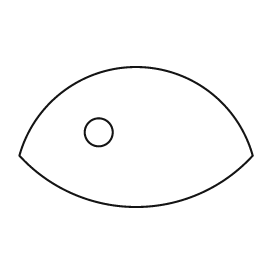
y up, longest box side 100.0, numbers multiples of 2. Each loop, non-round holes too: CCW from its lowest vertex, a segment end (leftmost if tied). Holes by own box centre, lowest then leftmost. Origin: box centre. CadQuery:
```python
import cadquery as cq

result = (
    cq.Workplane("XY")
    .moveTo(-50.0, -8.0)
    .threePointArc((0.0, -30.0), (50.0, -8.0))
    .threePointArc((0.0, 30.0), (-50.0, -8.0))
    .close()
    .moveTo(-16.0, 2.0)
    .circle(6.0)
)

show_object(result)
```